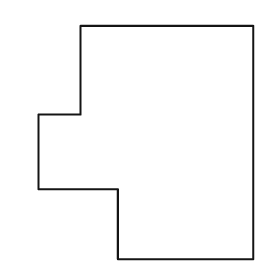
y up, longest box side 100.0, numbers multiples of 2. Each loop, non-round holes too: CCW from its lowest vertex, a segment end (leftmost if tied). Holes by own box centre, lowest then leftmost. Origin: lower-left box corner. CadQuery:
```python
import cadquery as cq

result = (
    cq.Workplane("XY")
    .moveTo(34.0, 0.0)
    .lineTo(92.0, 0.0)
    .lineTo(92.0, 100.0)
    .lineTo(18.0, 100.0)
    .lineTo(18.0, 62.0)
    .lineTo(0.0, 62.0)
    .lineTo(0.0, 30.0)
    .lineTo(34.0, 30.0)
    .close()
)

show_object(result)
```